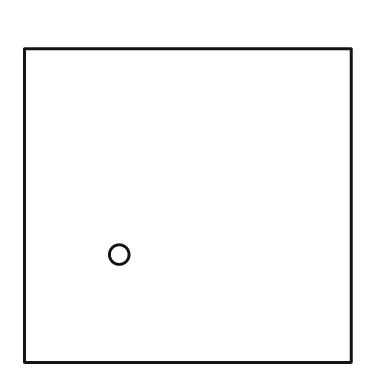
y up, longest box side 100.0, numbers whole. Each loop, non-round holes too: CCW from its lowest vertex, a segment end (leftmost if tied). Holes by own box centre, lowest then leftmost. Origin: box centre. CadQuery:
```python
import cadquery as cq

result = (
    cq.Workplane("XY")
    .moveTo(-50.0, -48.0)
    .lineTo(50.0, -48.0)
    .lineTo(50.0, 48.0)
    .lineTo(-50.0, 48.0)
    .close()
    .moveTo(-21.0, -15.0)
    .circle(3.0)
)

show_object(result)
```